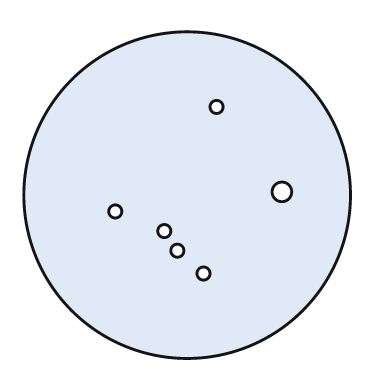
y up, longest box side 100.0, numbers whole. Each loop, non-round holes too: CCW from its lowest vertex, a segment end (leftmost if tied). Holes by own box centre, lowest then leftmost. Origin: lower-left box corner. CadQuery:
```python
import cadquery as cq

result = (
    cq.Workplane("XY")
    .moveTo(50.0, 50.0)
    .circle(50.0)
    .moveTo(55.0, 26.0)
    .circle(2.0)
    .moveTo(47.0, 33.0)
    .circle(2.0)
    .moveTo(43.0, 39.0)
    .circle(2.0)
    .moveTo(28.0, 45.0)
    .circle(2.0)
    .moveTo(79.0, 51.0)
    .circle(3.0)
    .moveTo(59.0, 77.0)
    .circle(2.0)
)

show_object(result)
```